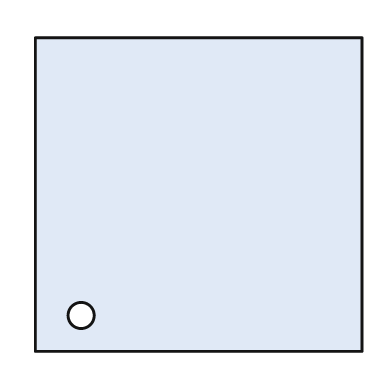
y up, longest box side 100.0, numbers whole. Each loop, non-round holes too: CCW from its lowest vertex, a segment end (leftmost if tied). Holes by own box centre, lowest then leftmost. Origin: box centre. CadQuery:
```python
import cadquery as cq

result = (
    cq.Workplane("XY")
    .moveTo(-50.0, -48.0)
    .lineTo(50.0, -48.0)
    .lineTo(50.0, 48.0)
    .lineTo(-50.0, 48.0)
    .close()
    .moveTo(-36.0, -37.0)
    .circle(4.0)
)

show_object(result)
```